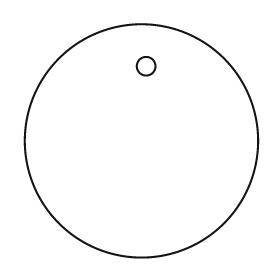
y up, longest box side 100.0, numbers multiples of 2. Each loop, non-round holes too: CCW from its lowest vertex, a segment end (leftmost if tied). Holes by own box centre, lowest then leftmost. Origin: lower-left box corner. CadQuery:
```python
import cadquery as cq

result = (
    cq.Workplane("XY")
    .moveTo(50.0, 50.0)
    .circle(50.0)
    .moveTo(52.0, 82.0)
    .circle(4.0)
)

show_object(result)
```